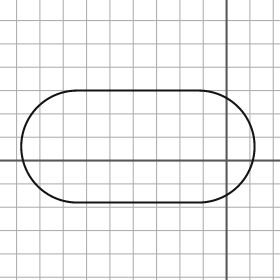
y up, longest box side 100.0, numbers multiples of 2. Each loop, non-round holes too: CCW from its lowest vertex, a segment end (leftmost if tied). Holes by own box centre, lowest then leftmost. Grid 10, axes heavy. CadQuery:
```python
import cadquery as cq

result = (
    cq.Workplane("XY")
    .moveTo(-64.0, -18.0)
    .lineTo(-12.0, -18.0)
    .threePointArc((12.0, 6.0), (-12.0, 30.0))
    .lineTo(-64.0, 30.0)
    .threePointArc((-88.0, 6.0), (-64.0, -18.0))
    .close()
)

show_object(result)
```